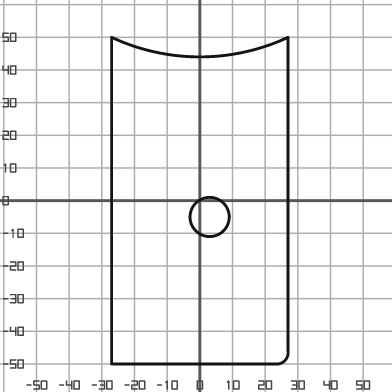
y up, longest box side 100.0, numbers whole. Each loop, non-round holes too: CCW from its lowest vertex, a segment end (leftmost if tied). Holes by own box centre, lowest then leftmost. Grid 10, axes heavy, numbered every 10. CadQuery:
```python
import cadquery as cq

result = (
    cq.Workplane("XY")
    .moveTo(-27.0, -50.0)
    .lineTo(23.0, -50.0)
    .threePointArc((26.0, -49.0), (27.0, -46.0))
    .lineTo(27.0, 50.0)
    .threePointArc((0.0, 44.0), (-27.0, 50.0))
    .close()
    .moveTo(3.0, -5.0)
    .circle(6.0)
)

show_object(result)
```